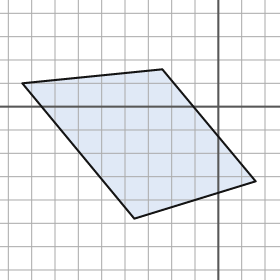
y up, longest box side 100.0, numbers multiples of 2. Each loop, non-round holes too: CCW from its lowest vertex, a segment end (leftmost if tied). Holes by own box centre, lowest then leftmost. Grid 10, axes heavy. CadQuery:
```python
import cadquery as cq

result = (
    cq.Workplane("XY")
    .moveTo(-36.0, -48.0)
    .lineTo(16.0, -32.0)
    .lineTo(-24.0, 16.0)
    .lineTo(-84.0, 10.0)
    .close()
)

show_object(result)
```